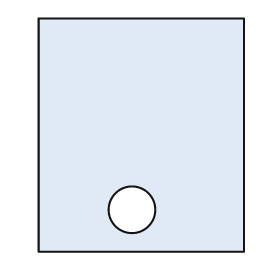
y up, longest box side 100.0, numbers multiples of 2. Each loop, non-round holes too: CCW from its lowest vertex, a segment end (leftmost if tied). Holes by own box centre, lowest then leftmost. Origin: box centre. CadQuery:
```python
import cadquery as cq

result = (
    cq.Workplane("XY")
    .moveTo(-44.0, -50.0)
    .lineTo(44.0, -50.0)
    .lineTo(44.0, 50.0)
    .lineTo(-44.0, 50.0)
    .close()
    .moveTo(-4.0, -32.0)
    .circle(10.0)
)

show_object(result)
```